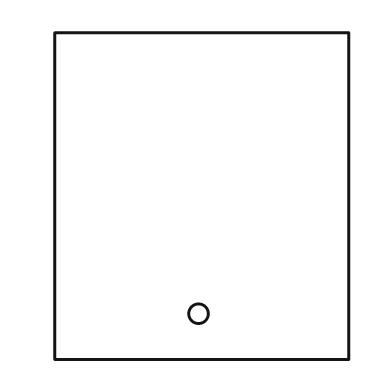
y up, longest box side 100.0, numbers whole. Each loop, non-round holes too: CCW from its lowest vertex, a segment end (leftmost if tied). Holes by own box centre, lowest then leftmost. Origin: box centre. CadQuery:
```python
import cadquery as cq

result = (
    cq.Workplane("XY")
    .moveTo(-45.0, -50.0)
    .lineTo(45.0, -50.0)
    .lineTo(45.0, 50.0)
    .lineTo(-45.0, 50.0)
    .close()
    .moveTo(-1.0, -36.0)
    .circle(3.0)
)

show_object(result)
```